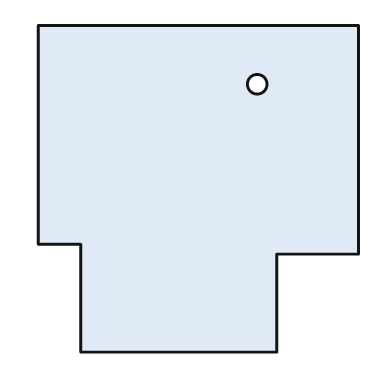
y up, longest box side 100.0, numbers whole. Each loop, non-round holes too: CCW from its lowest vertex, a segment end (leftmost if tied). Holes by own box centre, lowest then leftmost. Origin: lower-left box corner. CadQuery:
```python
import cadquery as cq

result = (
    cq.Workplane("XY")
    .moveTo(13.0, 0.0)
    .lineTo(73.0, 0.0)
    .lineTo(73.0, 30.0)
    .lineTo(98.0, 30.0)
    .lineTo(98.0, 100.0)
    .lineTo(0.0, 100.0)
    .lineTo(0.0, 33.0)
    .lineTo(13.0, 33.0)
    .close()
    .moveTo(67.0, 82.0)
    .circle(3.0)
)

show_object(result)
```